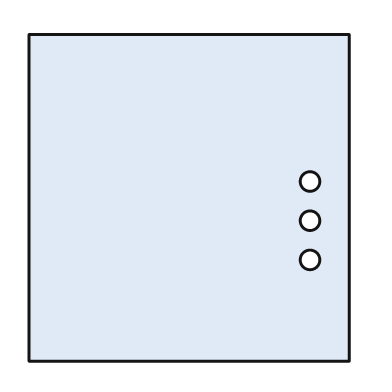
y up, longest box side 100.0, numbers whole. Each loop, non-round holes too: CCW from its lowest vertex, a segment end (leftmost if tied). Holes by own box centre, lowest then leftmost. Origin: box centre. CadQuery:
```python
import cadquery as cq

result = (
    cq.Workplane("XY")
    .moveTo(-49.0, -50.0)
    .lineTo(49.0, -50.0)
    .lineTo(49.0, 50.0)
    .lineTo(-49.0, 50.0)
    .close()
    .moveTo(37.0, -19.0)
    .circle(3.0)
    .moveTo(37.0, -7.0)
    .circle(3.0)
    .moveTo(37.0, 5.0)
    .circle(3.0)
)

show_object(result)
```